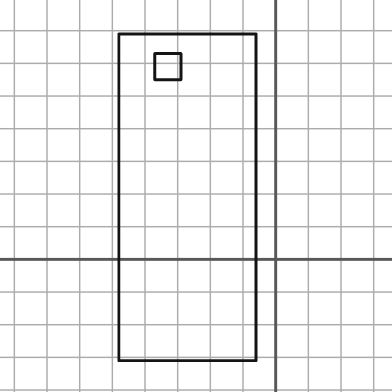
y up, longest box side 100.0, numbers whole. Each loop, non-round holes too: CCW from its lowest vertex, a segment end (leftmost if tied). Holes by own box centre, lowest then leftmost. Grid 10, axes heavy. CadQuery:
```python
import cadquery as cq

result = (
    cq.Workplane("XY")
    .moveTo(-48.0, -31.0)
    .lineTo(-6.0, -31.0)
    .lineTo(-6.0, 69.0)
    .lineTo(-48.0, 69.0)
    .close()
    .moveTo(-37.0, 55.0)
    .lineTo(-29.0, 55.0)
    .lineTo(-29.0, 63.0)
    .lineTo(-37.0, 63.0)
    .close()
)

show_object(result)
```